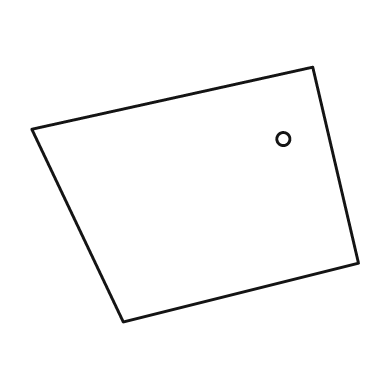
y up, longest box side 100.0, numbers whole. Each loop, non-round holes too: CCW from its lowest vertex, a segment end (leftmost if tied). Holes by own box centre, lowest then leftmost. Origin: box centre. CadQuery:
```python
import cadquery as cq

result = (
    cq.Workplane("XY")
    .moveTo(-22.0, -39.0)
    .lineTo(50.0, -21.0)
    .lineTo(36.0, 39.0)
    .lineTo(-50.0, 20.0)
    .close()
    .moveTo(27.0, 17.0)
    .circle(2.0)
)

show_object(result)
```